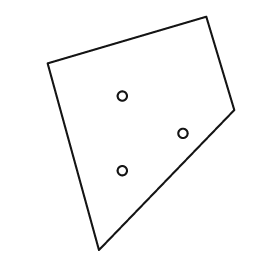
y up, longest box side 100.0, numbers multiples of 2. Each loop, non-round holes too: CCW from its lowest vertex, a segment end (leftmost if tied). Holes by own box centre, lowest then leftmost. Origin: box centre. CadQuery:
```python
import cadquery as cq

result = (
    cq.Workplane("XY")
    .moveTo(-18.0, -50.0)
    .lineTo(40.0, 10.0)
    .lineTo(28.0, 50.0)
    .lineTo(-40.0, 30.0)
    .close()
    .moveTo(-8.0, -16.0)
    .circle(2.0)
    .moveTo(18.0, 0.0)
    .circle(2.0)
    .moveTo(-8.0, 16.0)
    .circle(2.0)
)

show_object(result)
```